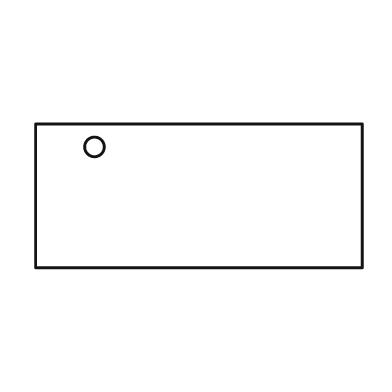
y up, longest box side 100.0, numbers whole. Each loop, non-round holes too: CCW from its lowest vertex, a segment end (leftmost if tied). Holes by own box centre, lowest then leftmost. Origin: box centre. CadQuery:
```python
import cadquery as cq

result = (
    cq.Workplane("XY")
    .moveTo(-50.0, -22.0)
    .lineTo(50.0, -22.0)
    .lineTo(50.0, 22.0)
    .lineTo(-50.0, 22.0)
    .close()
    .moveTo(-32.0, 15.0)
    .circle(3.0)
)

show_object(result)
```